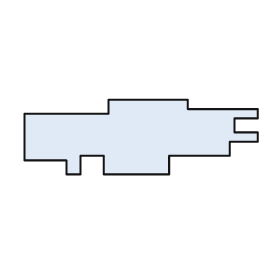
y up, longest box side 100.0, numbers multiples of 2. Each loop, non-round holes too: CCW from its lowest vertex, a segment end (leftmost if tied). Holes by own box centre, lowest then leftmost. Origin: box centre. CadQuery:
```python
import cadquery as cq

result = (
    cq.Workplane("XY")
    .moveTo(-32.0, -16.0)
    .lineTo(-26.0, -16.0)
    .lineTo(-26.0, -8.0)
    .lineTo(-16.0, -8.0)
    .lineTo(-16.0, -16.0)
    .lineTo(12.0, -16.0)
    .lineTo(12.0, -8.0)
    .lineTo(38.0, -8.0)
    .lineTo(38.0, -2.0)
    .lineTo(50.0, -2.0)
    .lineTo(50.0, 2.0)
    .lineTo(40.0, 2.0)
    .lineTo(40.0, 8.0)
    .lineTo(50.0, 8.0)
    .lineTo(50.0, 12.0)
    .lineTo(20.0, 12.0)
    .lineTo(20.0, 16.0)
    .lineTo(-14.0, 16.0)
    .lineTo(-14.0, 10.0)
    .lineTo(-50.0, 10.0)
    .lineTo(-50.0, -10.0)
    .lineTo(-32.0, -10.0)
    .close()
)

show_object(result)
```